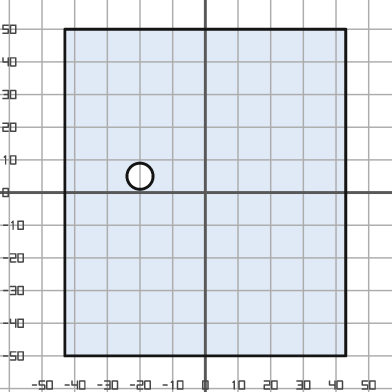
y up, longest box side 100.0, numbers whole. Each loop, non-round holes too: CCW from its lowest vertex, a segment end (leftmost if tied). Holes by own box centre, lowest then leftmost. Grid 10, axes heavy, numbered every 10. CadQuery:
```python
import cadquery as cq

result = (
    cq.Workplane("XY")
    .moveTo(-43.0, -50.0)
    .lineTo(43.0, -50.0)
    .lineTo(43.0, 50.0)
    .lineTo(-43.0, 50.0)
    .close()
    .moveTo(-20.0, 5.0)
    .circle(4.0)
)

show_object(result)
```